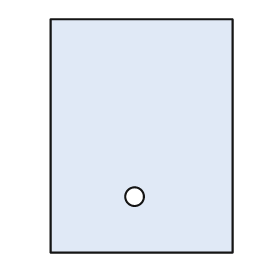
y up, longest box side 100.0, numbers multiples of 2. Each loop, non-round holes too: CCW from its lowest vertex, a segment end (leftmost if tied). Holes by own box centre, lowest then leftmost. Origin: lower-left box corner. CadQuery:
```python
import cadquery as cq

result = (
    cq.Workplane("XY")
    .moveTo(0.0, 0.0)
    .lineTo(78.0, 0.0)
    .lineTo(78.0, 100.0)
    .lineTo(0.0, 100.0)
    .close()
    .moveTo(36.0, 24.0)
    .circle(4.0)
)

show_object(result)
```